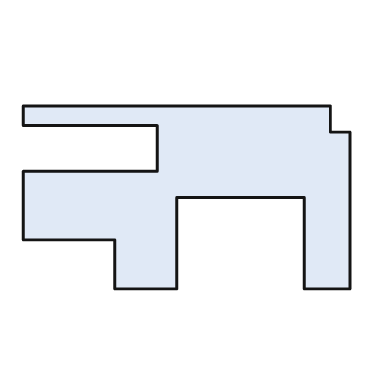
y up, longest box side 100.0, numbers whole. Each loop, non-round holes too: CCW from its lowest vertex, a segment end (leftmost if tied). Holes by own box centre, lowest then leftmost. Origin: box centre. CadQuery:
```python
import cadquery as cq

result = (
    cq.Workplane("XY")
    .moveTo(-22.0, -28.0)
    .lineTo(-3.0, -28.0)
    .lineTo(-3.0, 0.0)
    .lineTo(36.0, 0.0)
    .lineTo(36.0, -28.0)
    .lineTo(50.0, -28.0)
    .lineTo(50.0, 20.0)
    .lineTo(44.0, 20.0)
    .lineTo(44.0, 28.0)
    .lineTo(-50.0, 28.0)
    .lineTo(-50.0, 22.0)
    .lineTo(-9.0, 22.0)
    .lineTo(-9.0, 8.0)
    .lineTo(-50.0, 8.0)
    .lineTo(-50.0, -13.0)
    .lineTo(-22.0, -13.0)
    .close()
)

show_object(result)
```